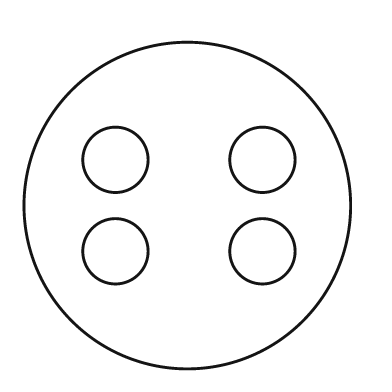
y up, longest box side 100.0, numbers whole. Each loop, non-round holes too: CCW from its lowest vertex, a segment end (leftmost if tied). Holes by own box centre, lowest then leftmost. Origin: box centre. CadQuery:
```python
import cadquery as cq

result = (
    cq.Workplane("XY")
    .moveTo(0.0, 0.0)
    .circle(50.0)
    .moveTo(-22.0, -14.0)
    .circle(10.0)
    .moveTo(23.0, -14.0)
    .circle(10.0)
    .moveTo(-22.0, 14.0)
    .circle(10.0)
    .moveTo(23.0, 14.0)
    .circle(10.0)
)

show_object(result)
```